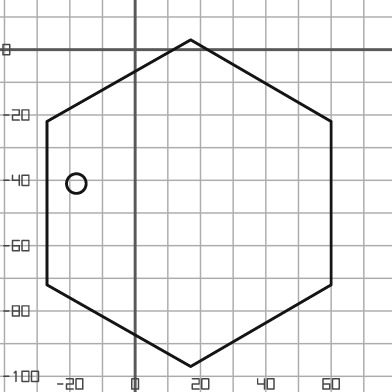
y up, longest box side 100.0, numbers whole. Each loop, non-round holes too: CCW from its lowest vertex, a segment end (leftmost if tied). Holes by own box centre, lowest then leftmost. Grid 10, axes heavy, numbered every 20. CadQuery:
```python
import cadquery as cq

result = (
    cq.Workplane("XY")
    .moveTo(17.0, -97.0)
    .lineTo(60.0, -72.0)
    .lineTo(60.0, -22.0)
    .lineTo(17.0, 3.0)
    .lineTo(-27.0, -22.0)
    .lineTo(-27.0, -72.0)
    .close()
    .moveTo(-18.0, -41.0)
    .circle(3.0)
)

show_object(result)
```